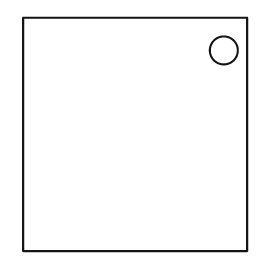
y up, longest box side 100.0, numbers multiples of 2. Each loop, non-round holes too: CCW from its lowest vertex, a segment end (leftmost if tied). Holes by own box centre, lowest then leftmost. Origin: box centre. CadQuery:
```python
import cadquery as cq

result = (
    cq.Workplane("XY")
    .moveTo(-48.0, -50.0)
    .lineTo(48.0, -50.0)
    .lineTo(48.0, 50.0)
    .lineTo(-48.0, 50.0)
    .close()
    .moveTo(38.0, 36.0)
    .circle(6.0)
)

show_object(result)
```